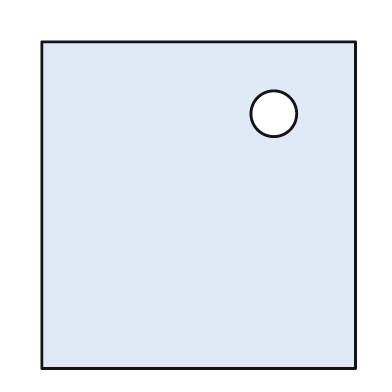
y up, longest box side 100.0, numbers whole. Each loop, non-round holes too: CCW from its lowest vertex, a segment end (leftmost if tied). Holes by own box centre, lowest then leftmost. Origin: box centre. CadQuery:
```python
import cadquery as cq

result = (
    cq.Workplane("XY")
    .moveTo(-48.0, -50.0)
    .lineTo(48.0, -50.0)
    .lineTo(48.0, 50.0)
    .lineTo(-48.0, 50.0)
    .close()
    .moveTo(23.0, 28.0)
    .circle(7.0)
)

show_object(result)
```